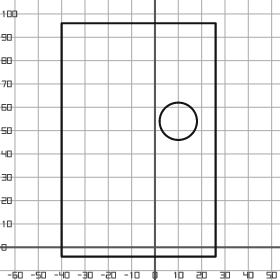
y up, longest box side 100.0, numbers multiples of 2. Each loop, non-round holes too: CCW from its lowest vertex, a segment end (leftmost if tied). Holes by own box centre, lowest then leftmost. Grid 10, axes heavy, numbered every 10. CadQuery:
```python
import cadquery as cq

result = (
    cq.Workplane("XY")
    .moveTo(-40.0, -4.0)
    .lineTo(26.0, -4.0)
    .lineTo(26.0, 96.0)
    .lineTo(-40.0, 96.0)
    .close()
    .moveTo(10.0, 54.0)
    .circle(8.0)
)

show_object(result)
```